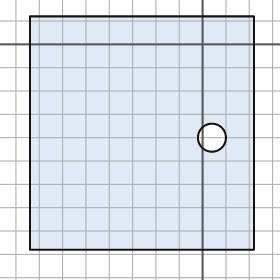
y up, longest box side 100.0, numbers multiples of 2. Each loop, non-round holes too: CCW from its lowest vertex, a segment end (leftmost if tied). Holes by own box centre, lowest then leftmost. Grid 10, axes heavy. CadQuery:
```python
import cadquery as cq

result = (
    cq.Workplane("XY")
    .moveTo(-74.0, -88.0)
    .lineTo(22.0, -88.0)
    .lineTo(22.0, 12.0)
    .lineTo(-74.0, 12.0)
    .close()
    .moveTo(4.0, -40.0)
    .circle(6.0)
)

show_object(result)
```